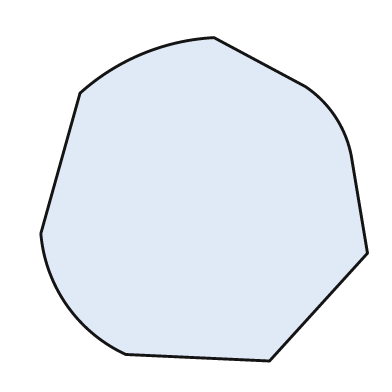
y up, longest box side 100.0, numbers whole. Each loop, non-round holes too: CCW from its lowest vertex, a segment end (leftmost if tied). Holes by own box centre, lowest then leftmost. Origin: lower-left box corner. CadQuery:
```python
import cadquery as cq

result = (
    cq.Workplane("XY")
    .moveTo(70.0, 0.0)
    .lineTo(100.0, 33.0)
    .lineTo(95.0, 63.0)
    .threePointArc((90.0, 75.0), (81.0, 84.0))
    .lineTo(53.0, 99.0)
    .threePointArc((31.0, 94.0), (12.0, 82.0))
    .lineTo(0.0, 39.0)
    .threePointArc((8.0, 17.0), (26.0, 2.0))
    .close()
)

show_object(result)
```